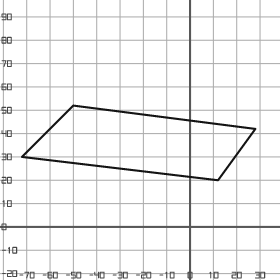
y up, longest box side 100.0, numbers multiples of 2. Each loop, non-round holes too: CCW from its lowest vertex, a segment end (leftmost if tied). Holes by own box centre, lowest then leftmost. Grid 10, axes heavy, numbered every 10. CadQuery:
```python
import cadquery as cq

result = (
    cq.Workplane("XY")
    .moveTo(12.0, 20.0)
    .lineTo(28.0, 42.0)
    .lineTo(-50.0, 52.0)
    .lineTo(-72.0, 30.0)
    .close()
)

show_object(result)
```